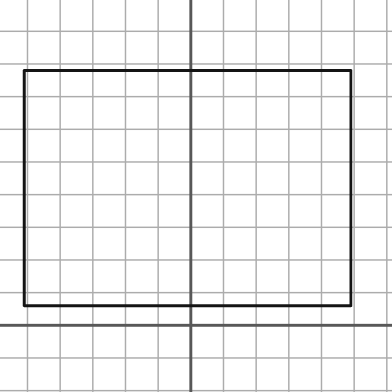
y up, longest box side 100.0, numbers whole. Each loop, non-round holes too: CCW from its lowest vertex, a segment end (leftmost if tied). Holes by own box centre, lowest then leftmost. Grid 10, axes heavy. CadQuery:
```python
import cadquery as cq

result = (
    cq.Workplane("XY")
    .moveTo(-51.0, 6.0)
    .lineTo(49.0, 6.0)
    .lineTo(49.0, 78.0)
    .lineTo(-51.0, 78.0)
    .close()
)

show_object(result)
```